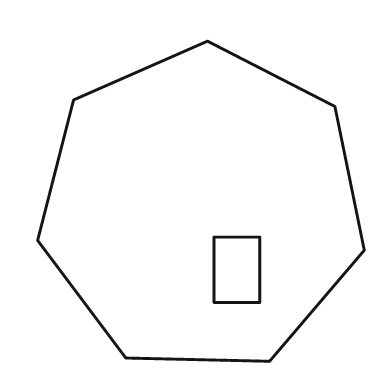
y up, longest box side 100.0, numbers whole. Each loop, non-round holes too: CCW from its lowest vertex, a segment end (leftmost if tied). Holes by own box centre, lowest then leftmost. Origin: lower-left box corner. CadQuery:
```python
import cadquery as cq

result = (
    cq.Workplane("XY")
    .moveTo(71.0, 0.0)
    .lineTo(100.0, 34.0)
    .lineTo(91.0, 78.0)
    .lineTo(52.0, 98.0)
    .lineTo(11.0, 80.0)
    .lineTo(0.0, 37.0)
    .lineTo(27.0, 1.0)
    .close()
    .moveTo(54.0, 18.0)
    .lineTo(68.0, 18.0)
    .lineTo(68.0, 38.0)
    .lineTo(54.0, 38.0)
    .close()
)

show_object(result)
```